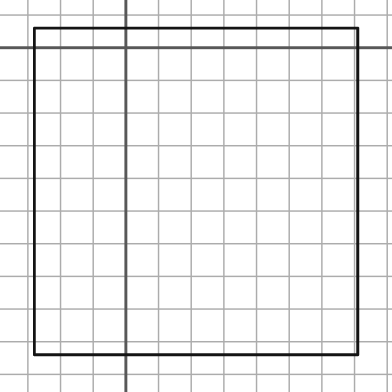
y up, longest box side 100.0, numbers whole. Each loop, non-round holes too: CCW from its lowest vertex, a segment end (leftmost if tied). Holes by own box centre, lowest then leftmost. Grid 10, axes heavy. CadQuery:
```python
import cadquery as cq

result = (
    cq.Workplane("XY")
    .moveTo(-28.0, -94.0)
    .lineTo(71.0, -94.0)
    .lineTo(71.0, 6.0)
    .lineTo(-28.0, 6.0)
    .close()
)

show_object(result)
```